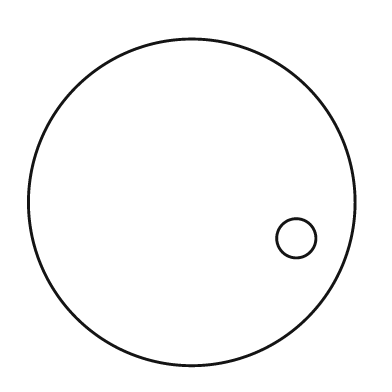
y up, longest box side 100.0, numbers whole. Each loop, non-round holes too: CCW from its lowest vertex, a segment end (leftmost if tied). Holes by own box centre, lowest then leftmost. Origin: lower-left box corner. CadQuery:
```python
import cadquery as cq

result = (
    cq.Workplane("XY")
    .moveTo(50.0, 50.0)
    .circle(50.0)
    .moveTo(82.0, 39.0)
    .circle(6.0)
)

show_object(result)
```